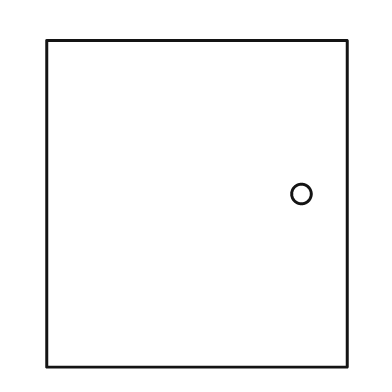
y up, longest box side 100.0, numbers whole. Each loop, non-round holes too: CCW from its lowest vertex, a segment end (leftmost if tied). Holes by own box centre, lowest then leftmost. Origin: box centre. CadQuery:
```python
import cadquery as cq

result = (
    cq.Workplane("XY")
    .moveTo(-46.0, -50.0)
    .lineTo(46.0, -50.0)
    .lineTo(46.0, 50.0)
    .lineTo(-46.0, 50.0)
    .close()
    .moveTo(32.0, 3.0)
    .circle(3.0)
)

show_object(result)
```